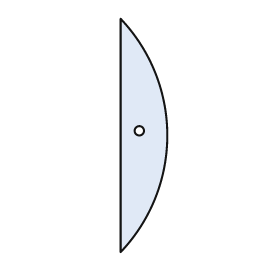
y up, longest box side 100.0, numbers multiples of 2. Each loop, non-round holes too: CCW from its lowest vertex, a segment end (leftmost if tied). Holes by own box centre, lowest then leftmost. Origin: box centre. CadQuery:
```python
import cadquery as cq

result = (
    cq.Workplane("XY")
    .moveTo(-10.0, -50.0)
    .threePointArc((10.0, 0.0), (-10.0, 50.0))
    .close()
    .moveTo(-2.0, 2.0)
    .circle(2.0)
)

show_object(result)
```